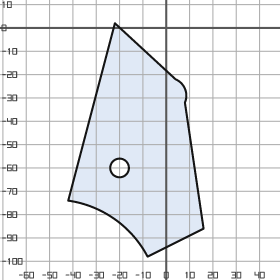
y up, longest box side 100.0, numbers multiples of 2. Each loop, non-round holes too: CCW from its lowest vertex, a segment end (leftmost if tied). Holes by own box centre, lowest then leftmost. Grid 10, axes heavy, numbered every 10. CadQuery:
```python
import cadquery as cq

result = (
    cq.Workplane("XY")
    .moveTo(-8.0, -98.0)
    .lineTo(16.0, -86.0)
    .lineTo(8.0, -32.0)
    .threePointArc((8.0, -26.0), (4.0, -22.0))
    .lineTo(-22.0, 2.0)
    .lineTo(-42.0, -74.0)
    .threePointArc((-22.0, -82.0), (-8.0, -98.0))
    .close()
    .moveTo(-20.0, -60.0)
    .circle(4.0)
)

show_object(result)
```